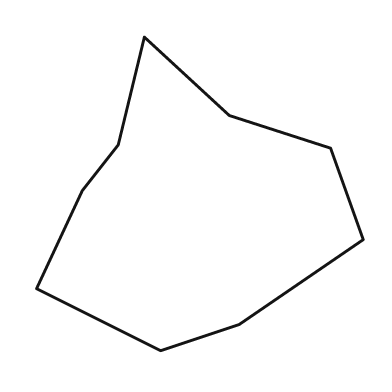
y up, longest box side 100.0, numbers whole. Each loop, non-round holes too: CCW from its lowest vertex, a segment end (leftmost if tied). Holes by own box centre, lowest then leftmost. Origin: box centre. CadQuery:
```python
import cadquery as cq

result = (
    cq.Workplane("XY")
    .moveTo(-12.0, -48.0)
    .lineTo(12.0, -40.0)
    .lineTo(50.0, -14.0)
    .lineTo(40.0, 14.0)
    .lineTo(9.0, 24.0)
    .lineTo(-17.0, 48.0)
    .lineTo(-25.0, 15.0)
    .lineTo(-36.0, 1.0)
    .lineTo(-50.0, -29.0)
    .close()
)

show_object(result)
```